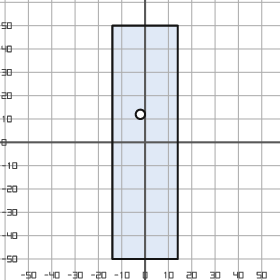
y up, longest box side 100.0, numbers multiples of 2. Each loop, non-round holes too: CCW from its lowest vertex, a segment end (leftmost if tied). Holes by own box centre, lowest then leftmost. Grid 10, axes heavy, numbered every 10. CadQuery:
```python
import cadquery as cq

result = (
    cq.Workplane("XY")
    .moveTo(-14.0, -50.0)
    .lineTo(14.0, -50.0)
    .lineTo(14.0, 50.0)
    .lineTo(-14.0, 50.0)
    .close()
    .moveTo(-2.0, 12.0)
    .circle(2.0)
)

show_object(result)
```